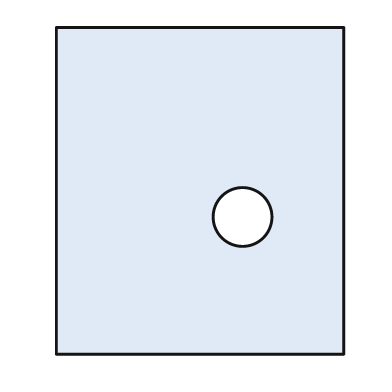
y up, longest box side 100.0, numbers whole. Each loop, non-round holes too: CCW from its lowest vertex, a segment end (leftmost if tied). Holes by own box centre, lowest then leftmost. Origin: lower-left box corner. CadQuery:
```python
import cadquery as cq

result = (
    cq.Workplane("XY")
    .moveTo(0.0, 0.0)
    .lineTo(88.0, 0.0)
    .lineTo(88.0, 100.0)
    .lineTo(0.0, 100.0)
    .close()
    .moveTo(57.0, 42.0)
    .circle(9.0)
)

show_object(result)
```